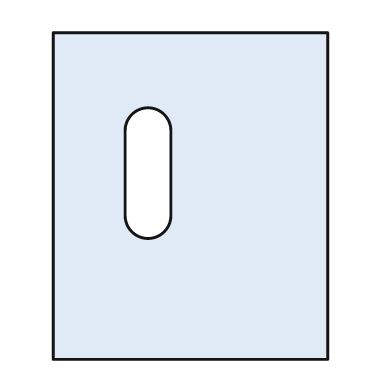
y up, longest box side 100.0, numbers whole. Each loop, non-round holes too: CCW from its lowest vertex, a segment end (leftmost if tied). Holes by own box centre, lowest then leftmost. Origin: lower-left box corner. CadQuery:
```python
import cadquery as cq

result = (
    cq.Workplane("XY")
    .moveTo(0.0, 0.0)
    .lineTo(84.0, 0.0)
    .lineTo(84.0, 100.0)
    .lineTo(0.0, 100.0)
    .close()
    .moveTo(22.0, 44.0)
    .threePointArc((29.0, 37.0), (36.0, 44.0))
    .lineTo(36.0, 70.0)
    .threePointArc((29.0, 77.0), (22.0, 70.0))
    .close()
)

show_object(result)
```